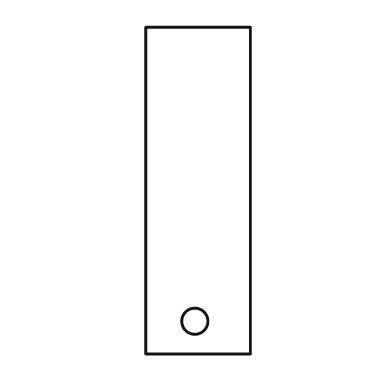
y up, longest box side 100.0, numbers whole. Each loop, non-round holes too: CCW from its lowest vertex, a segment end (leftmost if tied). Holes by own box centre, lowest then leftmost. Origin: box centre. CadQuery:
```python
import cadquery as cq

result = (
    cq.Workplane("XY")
    .moveTo(-16.0, -50.0)
    .lineTo(16.0, -50.0)
    .lineTo(16.0, 50.0)
    .lineTo(-16.0, 50.0)
    .close()
    .moveTo(-1.0, -40.0)
    .circle(4.0)
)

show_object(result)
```